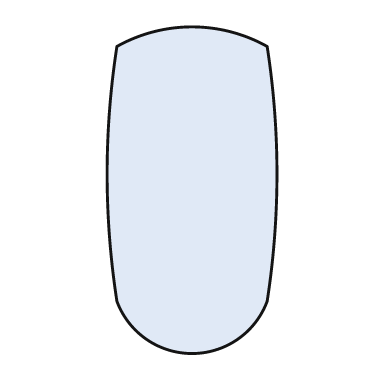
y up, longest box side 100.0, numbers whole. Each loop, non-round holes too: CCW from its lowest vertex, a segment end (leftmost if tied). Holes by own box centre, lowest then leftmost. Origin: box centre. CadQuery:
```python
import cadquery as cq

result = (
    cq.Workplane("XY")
    .moveTo(-23.0, -34.0)
    .threePointArc((0.0, -50.0), (23.0, -34.0))
    .threePointArc((26.0, 5.0), (23.0, 44.0))
    .threePointArc((0.0, 50.0), (-23.0, 44.0))
    .threePointArc((-26.0, 5.0), (-23.0, -34.0))
    .close()
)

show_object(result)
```